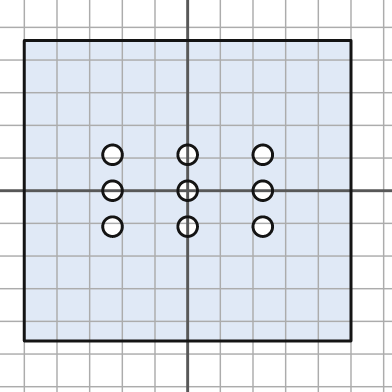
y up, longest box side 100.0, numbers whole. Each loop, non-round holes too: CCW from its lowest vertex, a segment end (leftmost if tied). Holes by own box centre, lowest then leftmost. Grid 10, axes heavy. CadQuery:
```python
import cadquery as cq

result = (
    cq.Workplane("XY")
    .moveTo(-50.0, -46.0)
    .lineTo(50.0, -46.0)
    .lineTo(50.0, 46.0)
    .lineTo(-50.0, 46.0)
    .close()
    .moveTo(-23.0, -11.0)
    .circle(3.0)
    .moveTo(0.0, -11.0)
    .circle(3.0)
    .moveTo(23.0, -11.0)
    .circle(3.0)
    .moveTo(-23.0, 0.0)
    .circle(3.0)
    .moveTo(0.0, 0.0)
    .circle(3.0)
    .moveTo(23.0, 0.0)
    .circle(3.0)
    .moveTo(-23.0, 11.0)
    .circle(3.0)
    .moveTo(0.0, 11.0)
    .circle(3.0)
    .moveTo(23.0, 11.0)
    .circle(3.0)
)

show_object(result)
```